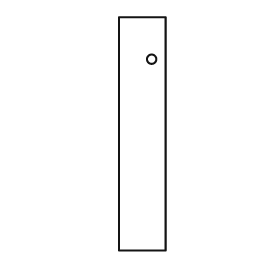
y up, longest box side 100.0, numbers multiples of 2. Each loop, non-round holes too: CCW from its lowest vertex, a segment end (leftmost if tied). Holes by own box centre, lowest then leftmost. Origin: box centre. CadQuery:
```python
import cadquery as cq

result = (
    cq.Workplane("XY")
    .moveTo(-10.0, -50.0)
    .lineTo(10.0, -50.0)
    .lineTo(10.0, 50.0)
    .lineTo(-10.0, 50.0)
    .close()
    .moveTo(4.0, 32.0)
    .circle(2.0)
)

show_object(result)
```